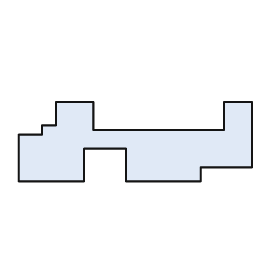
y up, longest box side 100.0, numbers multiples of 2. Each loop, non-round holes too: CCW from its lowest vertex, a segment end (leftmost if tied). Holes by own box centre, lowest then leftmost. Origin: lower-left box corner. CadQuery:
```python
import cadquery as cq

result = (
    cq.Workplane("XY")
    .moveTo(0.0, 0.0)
    .lineTo(28.0, 0.0)
    .lineTo(28.0, 14.0)
    .lineTo(46.0, 14.0)
    .lineTo(46.0, 0.0)
    .lineTo(78.0, 0.0)
    .lineTo(78.0, 6.0)
    .lineTo(100.0, 6.0)
    .lineTo(100.0, 34.0)
    .lineTo(88.0, 34.0)
    .lineTo(88.0, 22.0)
    .lineTo(32.0, 22.0)
    .lineTo(32.0, 34.0)
    .lineTo(16.0, 34.0)
    .lineTo(16.0, 24.0)
    .lineTo(10.0, 24.0)
    .lineTo(10.0, 20.0)
    .lineTo(0.0, 20.0)
    .close()
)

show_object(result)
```